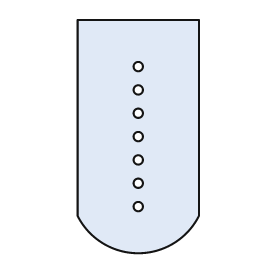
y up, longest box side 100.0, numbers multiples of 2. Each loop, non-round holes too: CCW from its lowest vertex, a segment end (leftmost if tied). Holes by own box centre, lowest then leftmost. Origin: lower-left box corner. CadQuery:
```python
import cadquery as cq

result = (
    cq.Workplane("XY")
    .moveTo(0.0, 16.0)
    .threePointArc((26.0, 0.0), (52.0, 16.0))
    .lineTo(52.0, 100.0)
    .lineTo(0.0, 100.0)
    .close()
    .moveTo(26.0, 20.0)
    .circle(2.0)
    .moveTo(26.0, 30.0)
    .circle(2.0)
    .moveTo(26.0, 40.0)
    .circle(2.0)
    .moveTo(26.0, 50.0)
    .circle(2.0)
    .moveTo(26.0, 60.0)
    .circle(2.0)
    .moveTo(26.0, 70.0)
    .circle(2.0)
    .moveTo(26.0, 80.0)
    .circle(2.0)
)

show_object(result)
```